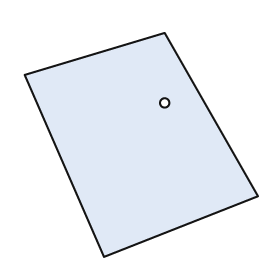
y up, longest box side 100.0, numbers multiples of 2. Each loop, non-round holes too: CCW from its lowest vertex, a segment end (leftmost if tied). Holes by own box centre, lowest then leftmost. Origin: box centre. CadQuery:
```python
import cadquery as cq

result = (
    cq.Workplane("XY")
    .moveTo(-16.0, -48.0)
    .lineTo(50.0, -22.0)
    .lineTo(10.0, 48.0)
    .lineTo(-50.0, 30.0)
    .close()
    .moveTo(10.0, 18.0)
    .circle(2.0)
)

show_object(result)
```